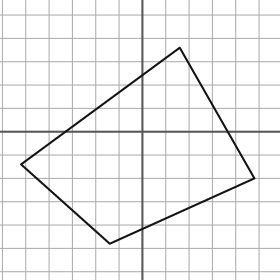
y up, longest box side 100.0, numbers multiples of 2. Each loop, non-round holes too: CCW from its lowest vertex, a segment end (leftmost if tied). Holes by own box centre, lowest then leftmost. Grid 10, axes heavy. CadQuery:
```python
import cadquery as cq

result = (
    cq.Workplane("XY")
    .moveTo(-14.0, -48.0)
    .lineTo(48.0, -20.0)
    .lineTo(16.0, 36.0)
    .lineTo(-52.0, -14.0)
    .close()
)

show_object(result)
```